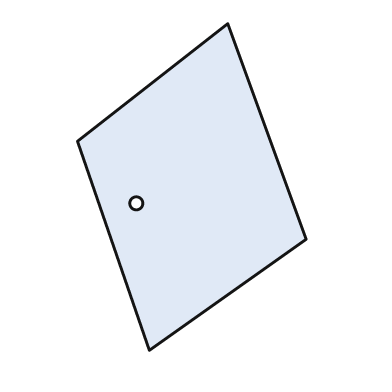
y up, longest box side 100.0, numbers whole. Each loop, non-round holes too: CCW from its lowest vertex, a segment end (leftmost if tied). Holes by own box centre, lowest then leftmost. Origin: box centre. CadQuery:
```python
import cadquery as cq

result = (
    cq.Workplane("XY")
    .moveTo(-13.0, -50.0)
    .lineTo(35.0, -16.0)
    .lineTo(11.0, 50.0)
    .lineTo(-35.0, 14.0)
    .close()
    .moveTo(-17.0, -5.0)
    .circle(2.0)
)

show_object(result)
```